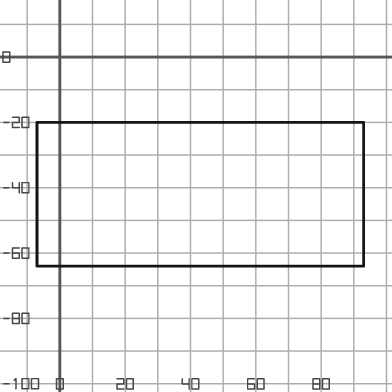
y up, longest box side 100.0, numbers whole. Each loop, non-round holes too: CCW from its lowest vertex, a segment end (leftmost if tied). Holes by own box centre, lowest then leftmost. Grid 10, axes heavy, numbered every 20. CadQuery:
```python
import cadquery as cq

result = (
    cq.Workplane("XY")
    .moveTo(-7.0, -64.0)
    .lineTo(93.0, -64.0)
    .lineTo(93.0, -20.0)
    .lineTo(-7.0, -20.0)
    .close()
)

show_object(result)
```